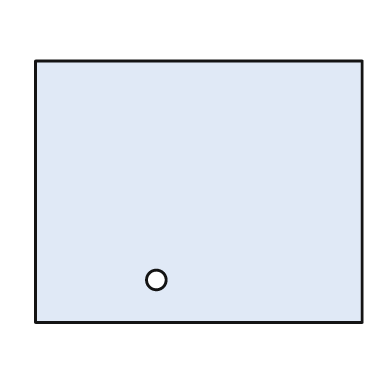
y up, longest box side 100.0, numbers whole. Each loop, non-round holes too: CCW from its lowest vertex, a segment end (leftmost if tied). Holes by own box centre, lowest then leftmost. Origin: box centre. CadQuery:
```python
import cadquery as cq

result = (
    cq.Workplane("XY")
    .moveTo(-50.0, -40.0)
    .lineTo(50.0, -40.0)
    .lineTo(50.0, 40.0)
    .lineTo(-50.0, 40.0)
    .close()
    .moveTo(-13.0, -27.0)
    .circle(3.0)
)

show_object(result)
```